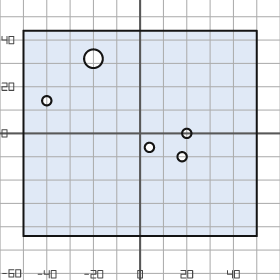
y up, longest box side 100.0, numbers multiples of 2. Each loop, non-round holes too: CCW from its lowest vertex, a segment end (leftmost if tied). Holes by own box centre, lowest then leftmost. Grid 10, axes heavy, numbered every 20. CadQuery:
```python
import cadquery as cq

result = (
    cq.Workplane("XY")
    .moveTo(-50.0, -44.0)
    .lineTo(50.0, -44.0)
    .lineTo(50.0, 44.0)
    .lineTo(-50.0, 44.0)
    .close()
    .moveTo(18.0, -10.0)
    .circle(2.0)
    .moveTo(4.0, -6.0)
    .circle(2.0)
    .moveTo(20.0, 0.0)
    .circle(2.0)
    .moveTo(-40.0, 14.0)
    .circle(2.0)
    .moveTo(-20.0, 32.0)
    .circle(4.0)
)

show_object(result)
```